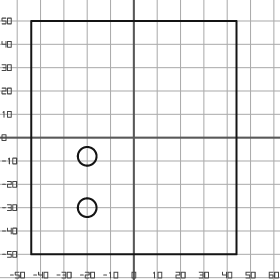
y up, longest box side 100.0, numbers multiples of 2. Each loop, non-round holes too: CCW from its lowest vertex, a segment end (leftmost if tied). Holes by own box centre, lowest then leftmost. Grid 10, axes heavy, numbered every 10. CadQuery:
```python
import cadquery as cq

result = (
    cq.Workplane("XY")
    .moveTo(-44.0, -50.0)
    .lineTo(44.0, -50.0)
    .lineTo(44.0, 50.0)
    .lineTo(-44.0, 50.0)
    .close()
    .moveTo(-20.0, -30.0)
    .circle(4.0)
    .moveTo(-20.0, -8.0)
    .circle(4.0)
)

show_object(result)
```